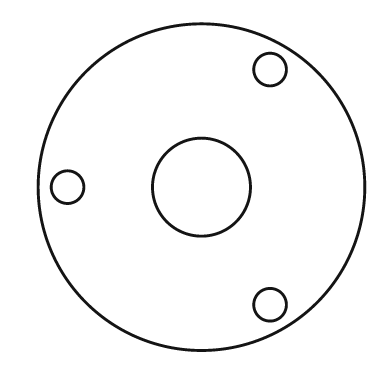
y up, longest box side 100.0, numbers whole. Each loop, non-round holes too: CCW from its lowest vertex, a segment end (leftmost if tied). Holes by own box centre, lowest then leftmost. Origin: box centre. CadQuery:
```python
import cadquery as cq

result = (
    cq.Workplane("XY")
    .moveTo(0.0, 0.0)
    .circle(50.0)
    .moveTo(21.0, -36.0)
    .circle(5.0)
    .moveTo(-41.0, 0.0)
    .circle(5.0)
    .moveTo(0.0, 0.0)
    .circle(15.0)
    .moveTo(21.0, 36.0)
    .circle(5.0)
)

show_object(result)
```